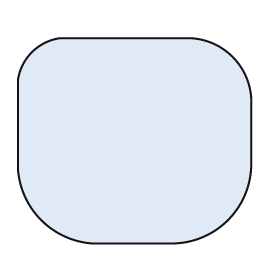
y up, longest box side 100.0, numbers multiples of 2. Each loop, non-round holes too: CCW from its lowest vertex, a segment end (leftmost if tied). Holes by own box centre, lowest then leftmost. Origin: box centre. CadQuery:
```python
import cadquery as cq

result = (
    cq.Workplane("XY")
    .moveTo(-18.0, -44.0)
    .lineTo(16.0, -44.0)
    .threePointArc((40.0, -34.0), (50.0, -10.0))
    .lineTo(50.0, 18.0)
    .threePointArc((42.0, 36.0), (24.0, 44.0))
    .lineTo(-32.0, 44.0)
    .threePointArc((-44.0, 38.0), (-50.0, 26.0))
    .lineTo(-50.0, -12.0)
    .threePointArc((-40.0, -34.0), (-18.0, -44.0))
    .close()
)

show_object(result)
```